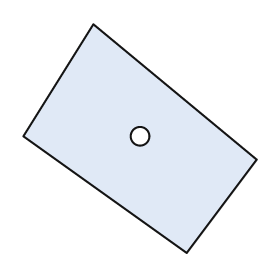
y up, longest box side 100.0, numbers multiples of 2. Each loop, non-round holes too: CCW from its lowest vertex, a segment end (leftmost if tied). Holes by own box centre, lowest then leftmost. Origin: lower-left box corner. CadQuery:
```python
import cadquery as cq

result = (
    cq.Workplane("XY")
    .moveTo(70.0, 0.0)
    .lineTo(100.0, 40.0)
    .lineTo(30.0, 98.0)
    .lineTo(0.0, 50.0)
    .close()
    .moveTo(50.0, 50.0)
    .circle(4.0)
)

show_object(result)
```